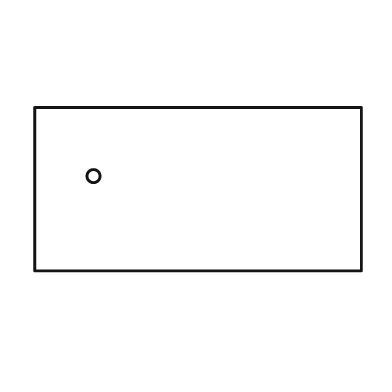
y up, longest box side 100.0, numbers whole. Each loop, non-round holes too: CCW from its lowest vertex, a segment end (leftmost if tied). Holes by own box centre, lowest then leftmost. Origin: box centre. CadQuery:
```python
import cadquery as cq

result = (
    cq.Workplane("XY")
    .moveTo(-50.0, -25.0)
    .lineTo(50.0, -25.0)
    .lineTo(50.0, 25.0)
    .lineTo(-50.0, 25.0)
    .close()
    .moveTo(-32.0, 4.0)
    .circle(2.0)
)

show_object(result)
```